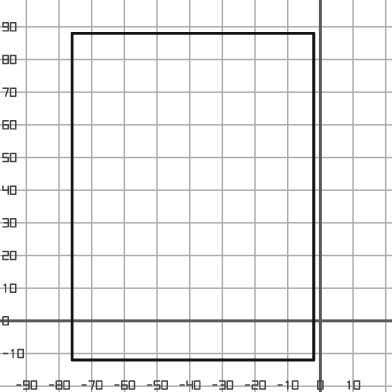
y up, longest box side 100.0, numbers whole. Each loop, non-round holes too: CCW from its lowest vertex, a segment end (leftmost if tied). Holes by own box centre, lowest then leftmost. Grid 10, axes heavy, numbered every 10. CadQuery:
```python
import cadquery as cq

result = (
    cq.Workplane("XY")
    .moveTo(-76.0, -12.0)
    .lineTo(-2.0, -12.0)
    .lineTo(-2.0, 88.0)
    .lineTo(-76.0, 88.0)
    .close()
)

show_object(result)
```